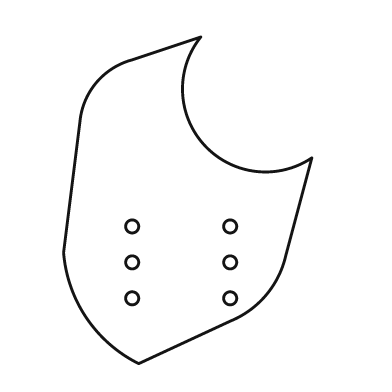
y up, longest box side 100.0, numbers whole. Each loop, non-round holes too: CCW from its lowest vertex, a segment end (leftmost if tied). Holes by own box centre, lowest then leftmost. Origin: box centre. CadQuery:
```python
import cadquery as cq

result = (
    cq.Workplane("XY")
    .moveTo(-15.0, -50.0)
    .lineTo(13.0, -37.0)
    .threePointArc((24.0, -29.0), (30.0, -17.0))
    .lineTo(38.0, 13.0)
    .threePointArc((5.0, 17.0), (4.0, 50.0))
    .lineTo(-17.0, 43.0)
    .threePointArc((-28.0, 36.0), (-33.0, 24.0))
    .lineTo(-38.0, -16.0)
    .threePointArc((-31.0, -36.0), (-15.0, -50.0))
    .close()
    .moveTo(-17.0, -30.0)
    .circle(2.0)
    .moveTo(13.0, -30.0)
    .circle(2.0)
    .moveTo(-17.0, -19.0)
    .circle(2.0)
    .moveTo(13.0, -19.0)
    .circle(2.0)
    .moveTo(-17.0, -8.0)
    .circle(2.0)
    .moveTo(13.0, -8.0)
    .circle(2.0)
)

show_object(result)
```